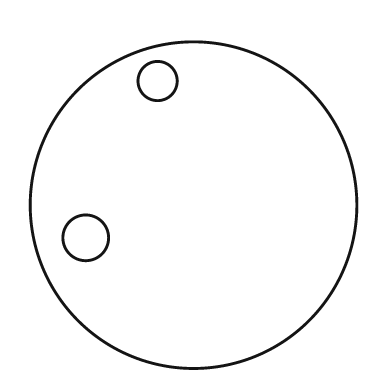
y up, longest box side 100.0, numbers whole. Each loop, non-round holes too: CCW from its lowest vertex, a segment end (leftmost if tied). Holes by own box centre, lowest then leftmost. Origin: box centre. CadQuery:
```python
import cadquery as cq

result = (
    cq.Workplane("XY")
    .moveTo(0.0, 0.0)
    .circle(50.0)
    .moveTo(-33.0, -10.0)
    .circle(7.0)
    .moveTo(-11.0, 38.0)
    .circle(6.0)
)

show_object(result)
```